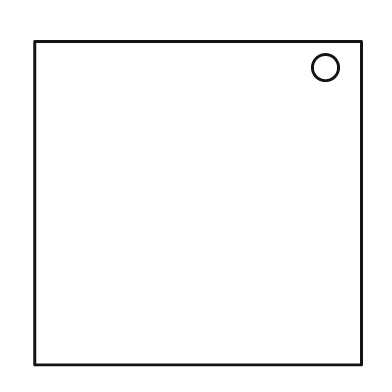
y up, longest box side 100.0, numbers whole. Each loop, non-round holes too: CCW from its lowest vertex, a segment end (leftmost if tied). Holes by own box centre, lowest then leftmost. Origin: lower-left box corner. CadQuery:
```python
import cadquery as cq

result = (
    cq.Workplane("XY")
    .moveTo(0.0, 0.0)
    .lineTo(100.0, 0.0)
    .lineTo(100.0, 99.0)
    .lineTo(0.0, 99.0)
    .close()
    .moveTo(89.0, 91.0)
    .circle(4.0)
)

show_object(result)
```